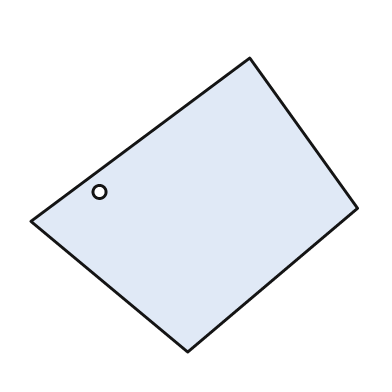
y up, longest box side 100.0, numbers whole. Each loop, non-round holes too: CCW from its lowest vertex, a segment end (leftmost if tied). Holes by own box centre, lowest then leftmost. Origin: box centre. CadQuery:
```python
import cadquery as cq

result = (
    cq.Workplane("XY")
    .moveTo(-2.0, -45.0)
    .lineTo(50.0, -1.0)
    .lineTo(17.0, 45.0)
    .lineTo(-50.0, -5.0)
    .close()
    .moveTo(-29.0, 4.0)
    .circle(2.0)
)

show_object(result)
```